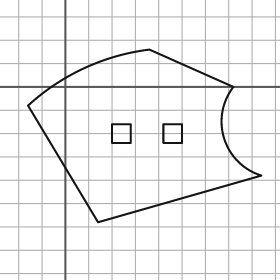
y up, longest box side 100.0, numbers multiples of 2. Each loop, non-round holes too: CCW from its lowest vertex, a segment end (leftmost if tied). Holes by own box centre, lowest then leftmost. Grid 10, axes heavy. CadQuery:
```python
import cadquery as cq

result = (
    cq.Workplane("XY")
    .moveTo(14.0, -58.0)
    .lineTo(84.0, -38.0)
    .threePointArc((68.0, -22.0), (72.0, 0.0))
    .lineTo(36.0, 16.0)
    .threePointArc((8.0, 8.0), (-16.0, -8.0))
    .close()
    .moveTo(20.0, -24.0)
    .lineTo(28.0, -24.0)
    .lineTo(28.0, -16.0)
    .lineTo(20.0, -16.0)
    .close()
    .moveTo(42.0, -24.0)
    .lineTo(50.0, -24.0)
    .lineTo(50.0, -16.0)
    .lineTo(42.0, -16.0)
    .close()
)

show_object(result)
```